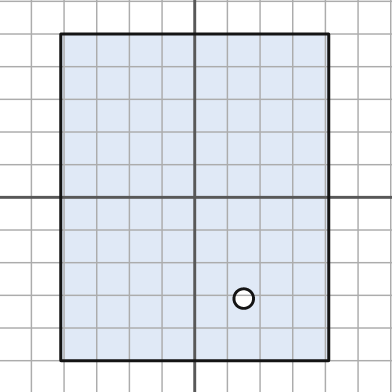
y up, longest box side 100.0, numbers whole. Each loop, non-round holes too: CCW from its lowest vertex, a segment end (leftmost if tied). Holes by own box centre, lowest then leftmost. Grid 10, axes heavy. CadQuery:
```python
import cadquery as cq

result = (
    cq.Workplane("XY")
    .moveTo(-41.0, -50.0)
    .lineTo(41.0, -50.0)
    .lineTo(41.0, 50.0)
    .lineTo(-41.0, 50.0)
    .close()
    .moveTo(15.0, -31.0)
    .circle(3.0)
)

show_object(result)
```